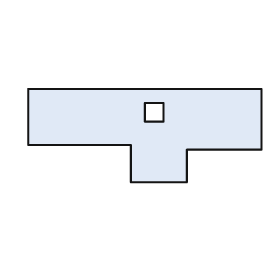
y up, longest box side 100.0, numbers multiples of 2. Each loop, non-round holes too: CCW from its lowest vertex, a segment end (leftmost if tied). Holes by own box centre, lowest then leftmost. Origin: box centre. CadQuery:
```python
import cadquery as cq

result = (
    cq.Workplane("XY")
    .moveTo(-6.0, -20.0)
    .lineTo(18.0, -20.0)
    .lineTo(18.0, -6.0)
    .lineTo(50.0, -6.0)
    .lineTo(50.0, 20.0)
    .lineTo(-50.0, 20.0)
    .lineTo(-50.0, -4.0)
    .lineTo(-6.0, -4.0)
    .close()
    .moveTo(0.0, 6.0)
    .lineTo(8.0, 6.0)
    .lineTo(8.0, 14.0)
    .lineTo(0.0, 14.0)
    .close()
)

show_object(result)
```